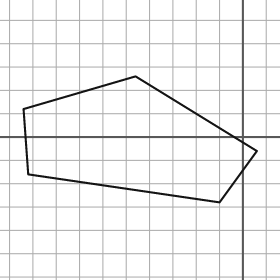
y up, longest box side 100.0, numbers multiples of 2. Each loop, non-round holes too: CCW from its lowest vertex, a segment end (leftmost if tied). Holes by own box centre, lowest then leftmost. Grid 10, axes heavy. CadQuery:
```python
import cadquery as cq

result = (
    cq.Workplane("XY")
    .moveTo(-10.0, -28.0)
    .lineTo(6.0, -6.0)
    .lineTo(-46.0, 26.0)
    .lineTo(-94.0, 12.0)
    .lineTo(-92.0, -16.0)
    .close()
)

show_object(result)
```